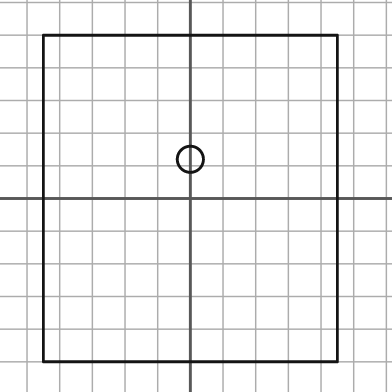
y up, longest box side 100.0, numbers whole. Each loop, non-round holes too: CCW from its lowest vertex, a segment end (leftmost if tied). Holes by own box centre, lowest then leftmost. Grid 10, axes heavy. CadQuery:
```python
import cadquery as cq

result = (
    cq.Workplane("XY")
    .moveTo(-45.0, -50.0)
    .lineTo(45.0, -50.0)
    .lineTo(45.0, 50.0)
    .lineTo(-45.0, 50.0)
    .close()
    .moveTo(0.0, 12.0)
    .circle(4.0)
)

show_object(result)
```